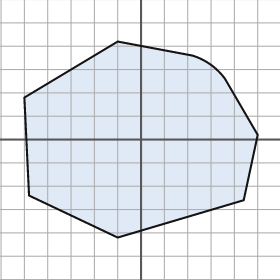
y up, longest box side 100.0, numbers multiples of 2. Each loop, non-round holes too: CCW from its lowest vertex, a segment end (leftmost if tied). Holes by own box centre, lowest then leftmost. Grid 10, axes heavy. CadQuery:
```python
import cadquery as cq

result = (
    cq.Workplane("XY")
    .moveTo(-10.0, -42.0)
    .lineTo(44.0, -26.0)
    .lineTo(50.0, 2.0)
    .lineTo(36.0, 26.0)
    .threePointArc((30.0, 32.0), (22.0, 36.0))
    .lineTo(-10.0, 42.0)
    .lineTo(-50.0, 18.0)
    .lineTo(-48.0, -24.0)
    .close()
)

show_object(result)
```